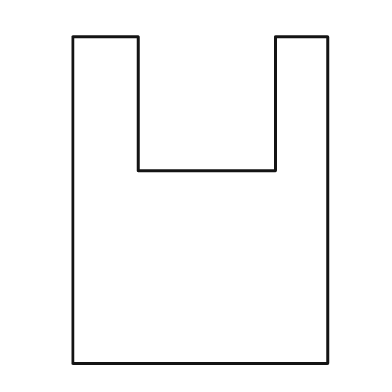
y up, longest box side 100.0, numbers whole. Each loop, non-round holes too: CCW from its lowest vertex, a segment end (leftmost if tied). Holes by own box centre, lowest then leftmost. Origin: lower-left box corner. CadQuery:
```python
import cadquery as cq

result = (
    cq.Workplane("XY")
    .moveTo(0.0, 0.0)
    .lineTo(78.0, 0.0)
    .lineTo(78.0, 100.0)
    .lineTo(62.0, 100.0)
    .lineTo(62.0, 59.0)
    .lineTo(20.0, 59.0)
    .lineTo(20.0, 100.0)
    .lineTo(0.0, 100.0)
    .close()
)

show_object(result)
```